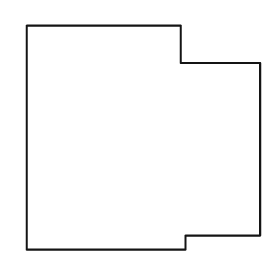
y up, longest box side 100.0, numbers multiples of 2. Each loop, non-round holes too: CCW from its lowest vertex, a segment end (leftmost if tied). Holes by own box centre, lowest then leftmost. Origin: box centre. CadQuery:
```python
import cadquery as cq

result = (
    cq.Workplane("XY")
    .moveTo(-50.0, -48.0)
    .lineTo(18.0, -48.0)
    .lineTo(18.0, -42.0)
    .lineTo(50.0, -42.0)
    .lineTo(50.0, 32.0)
    .lineTo(16.0, 32.0)
    .lineTo(16.0, 48.0)
    .lineTo(-50.0, 48.0)
    .close()
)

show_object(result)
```